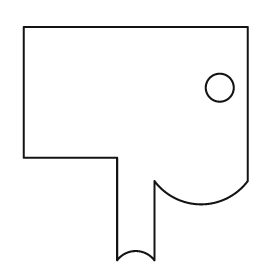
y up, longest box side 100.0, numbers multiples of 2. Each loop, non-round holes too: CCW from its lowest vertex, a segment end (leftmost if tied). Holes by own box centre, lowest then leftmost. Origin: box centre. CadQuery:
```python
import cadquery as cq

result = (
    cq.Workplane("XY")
    .moveTo(-8.0, -50.0)
    .threePointArc((0.0, -46.0), (8.0, -50.0))
    .lineTo(8.0, -16.0)
    .threePointArc((28.0, -26.0), (48.0, -16.0))
    .lineTo(48.0, 50.0)
    .lineTo(-48.0, 50.0)
    .lineTo(-48.0, -6.0)
    .lineTo(-8.0, -6.0)
    .close()
    .moveTo(36.0, 24.0)
    .circle(6.0)
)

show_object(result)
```